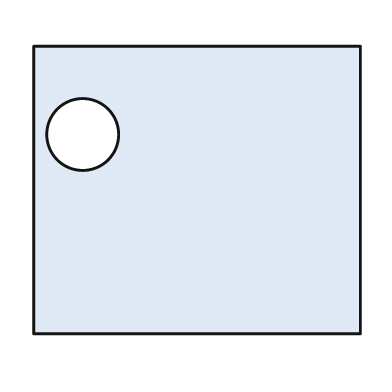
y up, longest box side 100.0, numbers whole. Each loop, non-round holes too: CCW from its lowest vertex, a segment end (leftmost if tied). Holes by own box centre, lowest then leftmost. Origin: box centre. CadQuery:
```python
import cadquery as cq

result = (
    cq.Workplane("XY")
    .moveTo(-50.0, -44.0)
    .lineTo(50.0, -44.0)
    .lineTo(50.0, 44.0)
    .lineTo(-50.0, 44.0)
    .close()
    .moveTo(-35.0, 17.0)
    .circle(11.0)
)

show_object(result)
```